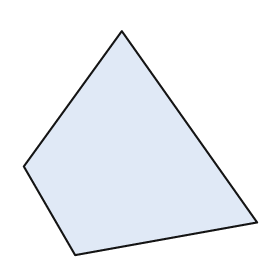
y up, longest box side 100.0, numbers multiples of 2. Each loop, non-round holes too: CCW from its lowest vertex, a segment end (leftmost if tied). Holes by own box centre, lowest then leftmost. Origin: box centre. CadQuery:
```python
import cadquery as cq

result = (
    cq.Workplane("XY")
    .moveTo(-28.0, -48.0)
    .lineTo(50.0, -34.0)
    .lineTo(-8.0, 48.0)
    .lineTo(-50.0, -10.0)
    .close()
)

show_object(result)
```